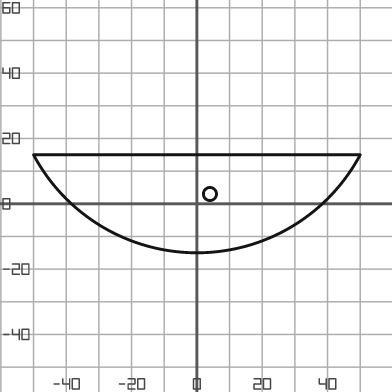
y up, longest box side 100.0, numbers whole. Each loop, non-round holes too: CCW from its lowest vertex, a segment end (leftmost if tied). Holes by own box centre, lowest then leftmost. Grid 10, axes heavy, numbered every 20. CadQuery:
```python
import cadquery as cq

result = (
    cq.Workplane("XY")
    .moveTo(-50.0, 15.0)
    .threePointArc((0.0, -15.0), (50.0, 15.0))
    .close()
    .moveTo(4.0, 3.0)
    .circle(2.0)
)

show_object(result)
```